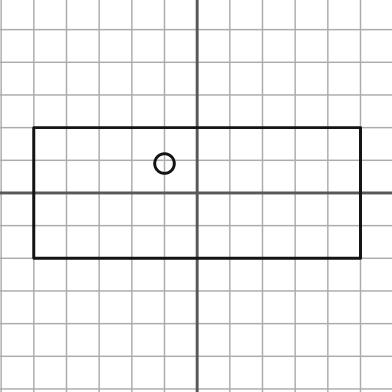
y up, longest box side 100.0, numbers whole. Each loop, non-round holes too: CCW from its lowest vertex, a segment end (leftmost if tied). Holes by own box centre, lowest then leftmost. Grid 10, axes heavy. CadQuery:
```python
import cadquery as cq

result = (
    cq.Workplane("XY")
    .moveTo(-50.0, -20.0)
    .lineTo(50.0, -20.0)
    .lineTo(50.0, 20.0)
    .lineTo(-50.0, 20.0)
    .close()
    .moveTo(-10.0, 9.0)
    .circle(3.0)
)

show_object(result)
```